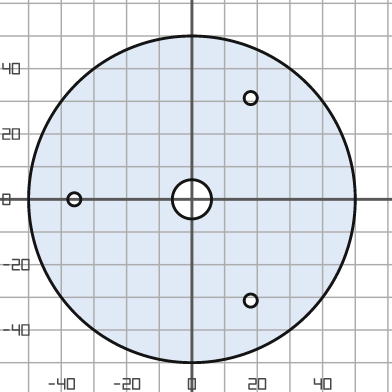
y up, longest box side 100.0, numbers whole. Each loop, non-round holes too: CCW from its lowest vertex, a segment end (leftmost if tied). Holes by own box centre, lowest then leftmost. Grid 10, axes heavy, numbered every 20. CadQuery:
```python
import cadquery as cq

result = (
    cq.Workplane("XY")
    .moveTo(0.0, 0.0)
    .circle(50.0)
    .moveTo(18.0, -31.0)
    .circle(2.0)
    .moveTo(-36.0, 0.0)
    .circle(2.0)
    .moveTo(0.0, 0.0)
    .circle(6.0)
    .moveTo(18.0, 31.0)
    .circle(2.0)
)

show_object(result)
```